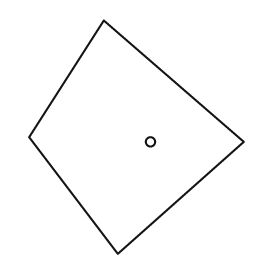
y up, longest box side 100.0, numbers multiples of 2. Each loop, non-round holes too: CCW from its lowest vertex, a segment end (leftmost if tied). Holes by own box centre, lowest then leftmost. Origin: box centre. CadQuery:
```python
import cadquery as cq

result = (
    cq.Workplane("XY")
    .moveTo(-8.0, -50.0)
    .lineTo(46.0, -2.0)
    .lineTo(-14.0, 50.0)
    .lineTo(-46.0, 0.0)
    .close()
    .moveTo(6.0, -2.0)
    .circle(2.0)
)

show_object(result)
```